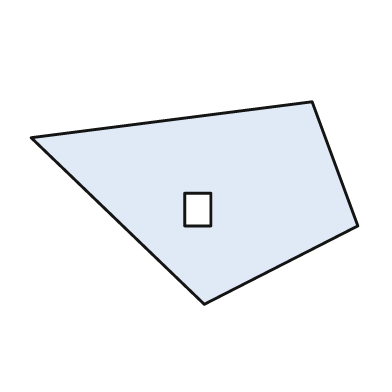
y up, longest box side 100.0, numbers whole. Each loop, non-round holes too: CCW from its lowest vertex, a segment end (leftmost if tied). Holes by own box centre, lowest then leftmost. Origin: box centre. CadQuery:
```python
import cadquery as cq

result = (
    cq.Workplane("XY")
    .moveTo(3.0, -31.0)
    .lineTo(50.0, -7.0)
    .lineTo(36.0, 31.0)
    .lineTo(-50.0, 20.0)
    .close()
    .moveTo(-3.0, -7.0)
    .lineTo(5.0, -7.0)
    .lineTo(5.0, 3.0)
    .lineTo(-3.0, 3.0)
    .close()
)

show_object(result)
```